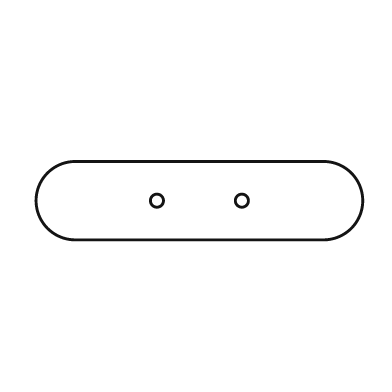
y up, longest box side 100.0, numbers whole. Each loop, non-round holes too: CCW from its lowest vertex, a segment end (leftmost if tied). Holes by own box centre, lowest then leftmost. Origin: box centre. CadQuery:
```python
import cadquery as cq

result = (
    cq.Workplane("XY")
    .moveTo(-38.0, -12.0)
    .lineTo(38.0, -12.0)
    .threePointArc((50.0, 0.0), (38.0, 12.0))
    .lineTo(-38.0, 12.0)
    .threePointArc((-50.0, 0.0), (-38.0, -12.0))
    .close()
    .moveTo(-13.0, 0.0)
    .circle(2.0)
    .moveTo(13.0, 0.0)
    .circle(2.0)
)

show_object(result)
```